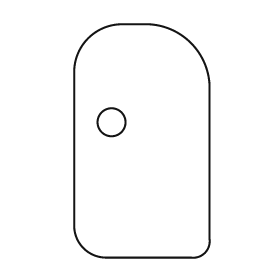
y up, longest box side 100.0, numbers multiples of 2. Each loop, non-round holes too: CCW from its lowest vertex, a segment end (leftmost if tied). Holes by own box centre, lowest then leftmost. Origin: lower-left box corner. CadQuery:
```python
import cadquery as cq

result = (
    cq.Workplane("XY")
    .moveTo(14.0, 0.0)
    .lineTo(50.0, 0.0)
    .threePointArc((56.0, 2.0), (58.0, 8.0))
    .lineTo(58.0, 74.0)
    .threePointArc((50.0, 92.0), (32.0, 100.0))
    .lineTo(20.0, 100.0)
    .threePointArc((6.0, 94.0), (0.0, 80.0))
    .lineTo(0.0, 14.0)
    .threePointArc((4.0, 4.0), (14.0, 0.0))
    .close()
    .moveTo(16.0, 58.0)
    .circle(6.0)
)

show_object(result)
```